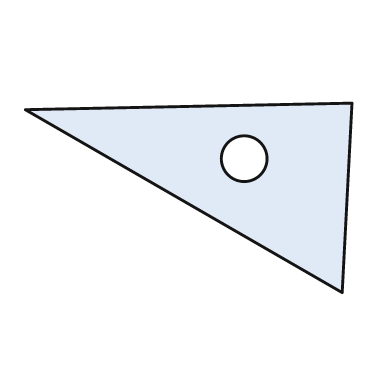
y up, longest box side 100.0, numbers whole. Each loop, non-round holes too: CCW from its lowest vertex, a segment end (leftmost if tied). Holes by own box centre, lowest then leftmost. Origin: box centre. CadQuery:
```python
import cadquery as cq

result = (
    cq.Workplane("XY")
    .moveTo(47.0, -29.0)
    .lineTo(50.0, 29.0)
    .lineTo(-50.0, 27.0)
    .close()
    .moveTo(17.0, 12.0)
    .circle(7.0)
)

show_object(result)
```